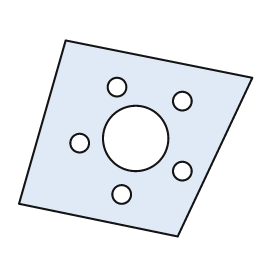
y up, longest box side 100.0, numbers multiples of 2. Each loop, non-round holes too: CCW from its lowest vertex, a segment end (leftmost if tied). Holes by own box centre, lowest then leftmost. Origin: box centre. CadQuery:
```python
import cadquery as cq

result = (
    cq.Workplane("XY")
    .moveTo(18.0, -42.0)
    .lineTo(50.0, 26.0)
    .lineTo(-30.0, 42.0)
    .lineTo(-50.0, -28.0)
    .close()
    .moveTo(-6.0, -24.0)
    .circle(4.0)
    .moveTo(20.0, -14.0)
    .circle(4.0)
    .moveTo(-24.0, -2.0)
    .circle(4.0)
    .moveTo(0.0, 0.0)
    .circle(14.0)
    .moveTo(20.0, 16.0)
    .circle(4.0)
    .moveTo(-8.0, 22.0)
    .circle(4.0)
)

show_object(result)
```